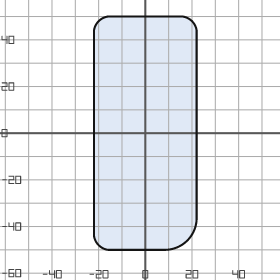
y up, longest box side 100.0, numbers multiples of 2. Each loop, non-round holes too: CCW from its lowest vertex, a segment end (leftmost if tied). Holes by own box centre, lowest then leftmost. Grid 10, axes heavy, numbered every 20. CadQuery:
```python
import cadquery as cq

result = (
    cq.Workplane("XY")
    .moveTo(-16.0, -50.0)
    .lineTo(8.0, -50.0)
    .threePointArc((18.0, -46.0), (22.0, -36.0))
    .lineTo(22.0, 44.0)
    .threePointArc((20.0, 48.0), (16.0, 50.0))
    .lineTo(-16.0, 50.0)
    .threePointArc((-20.0, 48.0), (-22.0, 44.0))
    .lineTo(-22.0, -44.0)
    .threePointArc((-20.0, -48.0), (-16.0, -50.0))
    .close()
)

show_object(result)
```